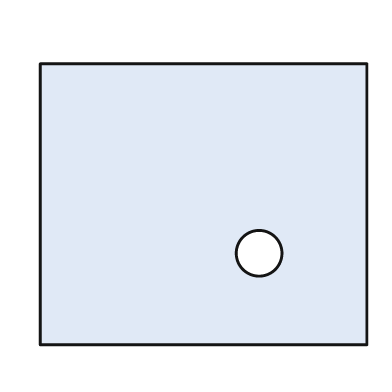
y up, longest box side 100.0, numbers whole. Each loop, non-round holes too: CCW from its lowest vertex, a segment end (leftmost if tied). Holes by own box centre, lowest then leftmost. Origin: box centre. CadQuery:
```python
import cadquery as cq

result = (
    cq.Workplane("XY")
    .moveTo(-50.0, -43.0)
    .lineTo(50.0, -43.0)
    .lineTo(50.0, 43.0)
    .lineTo(-50.0, 43.0)
    .close()
    .moveTo(17.0, -15.0)
    .circle(7.0)
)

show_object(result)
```